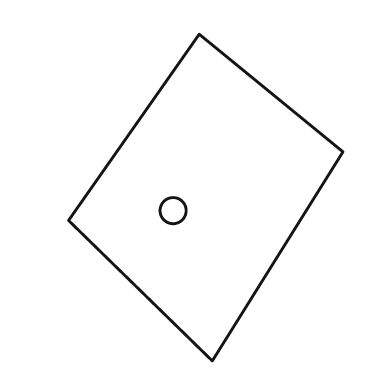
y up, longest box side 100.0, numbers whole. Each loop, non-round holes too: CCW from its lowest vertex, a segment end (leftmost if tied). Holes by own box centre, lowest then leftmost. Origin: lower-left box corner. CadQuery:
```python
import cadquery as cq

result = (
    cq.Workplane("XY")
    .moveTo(44.0, 0.0)
    .lineTo(84.0, 64.0)
    .lineTo(40.0, 100.0)
    .lineTo(0.0, 43.0)
    .close()
    .moveTo(32.0, 46.0)
    .circle(4.0)
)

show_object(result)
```